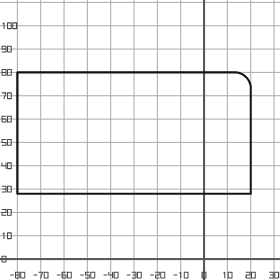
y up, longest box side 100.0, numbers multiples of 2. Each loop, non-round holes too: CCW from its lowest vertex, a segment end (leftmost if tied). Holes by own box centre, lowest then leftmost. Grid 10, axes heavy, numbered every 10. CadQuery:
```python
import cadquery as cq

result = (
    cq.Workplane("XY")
    .moveTo(-80.0, 28.0)
    .lineTo(20.0, 28.0)
    .lineTo(20.0, 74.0)
    .threePointArc((18.0, 78.0), (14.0, 80.0))
    .lineTo(-80.0, 80.0)
    .close()
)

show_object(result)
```